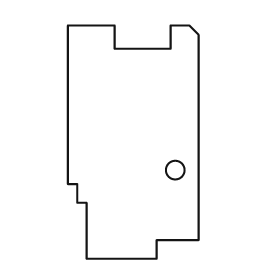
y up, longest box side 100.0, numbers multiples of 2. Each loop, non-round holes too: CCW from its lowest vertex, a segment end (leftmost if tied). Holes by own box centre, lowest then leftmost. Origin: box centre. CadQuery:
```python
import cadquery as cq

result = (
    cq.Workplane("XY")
    .moveTo(-20.0, -50.0)
    .lineTo(10.0, -50.0)
    .lineTo(10.0, -42.0)
    .lineTo(28.0, -42.0)
    .lineTo(28.0, 46.0)
    .lineTo(24.0, 50.0)
    .lineTo(16.0, 50.0)
    .lineTo(16.0, 40.0)
    .lineTo(-8.0, 40.0)
    .lineTo(-8.0, 50.0)
    .lineTo(-28.0, 50.0)
    .lineTo(-28.0, -18.0)
    .lineTo(-24.0, -18.0)
    .lineTo(-24.0, -26.0)
    .lineTo(-20.0, -26.0)
    .close()
    .moveTo(18.0, -12.0)
    .circle(4.0)
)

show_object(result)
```